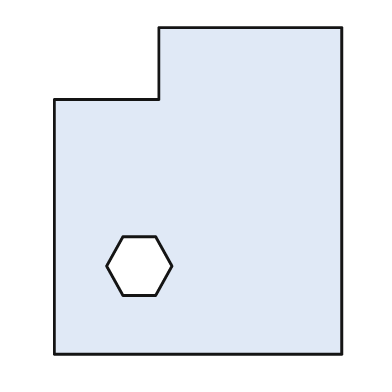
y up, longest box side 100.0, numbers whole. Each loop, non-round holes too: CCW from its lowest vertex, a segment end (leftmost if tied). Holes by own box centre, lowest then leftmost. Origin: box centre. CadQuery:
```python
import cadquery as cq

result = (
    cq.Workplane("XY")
    .moveTo(-44.0, -50.0)
    .lineTo(44.0, -50.0)
    .lineTo(44.0, 50.0)
    .lineTo(-12.0, 50.0)
    .lineTo(-12.0, 28.0)
    .lineTo(-44.0, 28.0)
    .close()
    .moveTo(-23.0, -32.0)
    .lineTo(-13.0, -32.0)
    .lineTo(-8.0, -23.0)
    .lineTo(-13.0, -14.0)
    .lineTo(-23.0, -14.0)
    .lineTo(-28.0, -23.0)
    .close()
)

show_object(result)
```